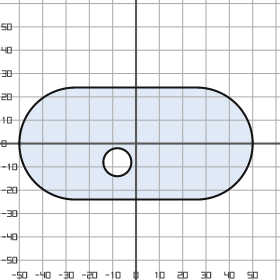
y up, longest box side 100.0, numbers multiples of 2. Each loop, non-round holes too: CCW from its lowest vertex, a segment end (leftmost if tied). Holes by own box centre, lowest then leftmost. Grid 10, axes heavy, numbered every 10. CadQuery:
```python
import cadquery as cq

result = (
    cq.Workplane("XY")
    .moveTo(-26.0, -24.0)
    .lineTo(26.0, -24.0)
    .threePointArc((50.0, 0.0), (26.0, 24.0))
    .lineTo(-26.0, 24.0)
    .threePointArc((-50.0, 0.0), (-26.0, -24.0))
    .close()
    .moveTo(-8.0, -8.0)
    .circle(6.0)
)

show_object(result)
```